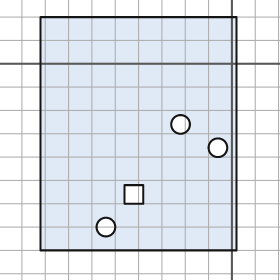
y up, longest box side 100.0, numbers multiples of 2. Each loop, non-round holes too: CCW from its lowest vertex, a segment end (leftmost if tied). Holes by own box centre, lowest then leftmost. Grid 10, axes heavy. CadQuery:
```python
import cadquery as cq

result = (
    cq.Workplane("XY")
    .moveTo(-82.0, -80.0)
    .lineTo(2.0, -80.0)
    .lineTo(2.0, 20.0)
    .lineTo(-82.0, 20.0)
    .close()
    .moveTo(-54.0, -70.0)
    .circle(4.0)
    .moveTo(-46.0, -60.0)
    .lineTo(-38.0, -60.0)
    .lineTo(-38.0, -52.0)
    .lineTo(-46.0, -52.0)
    .close()
    .moveTo(-6.0, -36.0)
    .circle(4.0)
    .moveTo(-22.0, -26.0)
    .circle(4.0)
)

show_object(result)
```